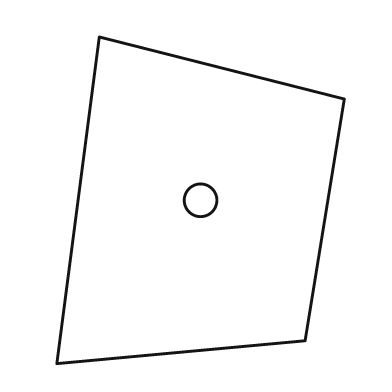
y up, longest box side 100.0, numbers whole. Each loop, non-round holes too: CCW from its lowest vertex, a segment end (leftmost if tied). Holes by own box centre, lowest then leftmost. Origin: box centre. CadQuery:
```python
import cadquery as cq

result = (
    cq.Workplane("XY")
    .moveTo(-44.0, -50.0)
    .lineTo(32.0, -43.0)
    .lineTo(44.0, 31.0)
    .lineTo(-31.0, 50.0)
    .close()
    .moveTo(0.0, 0.0)
    .circle(5.0)
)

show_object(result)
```